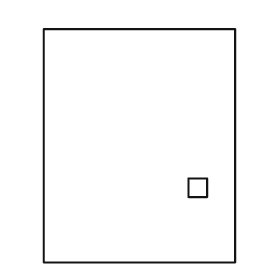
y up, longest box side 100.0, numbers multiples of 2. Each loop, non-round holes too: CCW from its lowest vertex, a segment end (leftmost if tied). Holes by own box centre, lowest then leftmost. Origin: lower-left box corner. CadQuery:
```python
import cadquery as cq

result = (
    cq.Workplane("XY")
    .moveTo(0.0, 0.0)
    .lineTo(82.0, 0.0)
    .lineTo(82.0, 100.0)
    .lineTo(0.0, 100.0)
    .close()
    .moveTo(62.0, 28.0)
    .lineTo(70.0, 28.0)
    .lineTo(70.0, 36.0)
    .lineTo(62.0, 36.0)
    .close()
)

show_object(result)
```